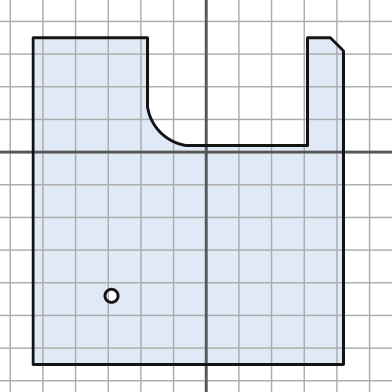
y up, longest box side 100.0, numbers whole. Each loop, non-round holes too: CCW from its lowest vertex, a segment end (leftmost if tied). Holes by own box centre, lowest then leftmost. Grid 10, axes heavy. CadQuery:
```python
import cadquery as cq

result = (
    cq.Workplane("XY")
    .moveTo(-53.0, -65.0)
    .lineTo(42.0, -65.0)
    .lineTo(42.0, 31.0)
    .lineTo(38.0, 35.0)
    .lineTo(31.0, 35.0)
    .lineTo(31.0, 2.0)
    .lineTo(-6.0, 2.0)
    .threePointArc((-14.0, 6.0), (-18.0, 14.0))
    .lineTo(-18.0, 35.0)
    .lineTo(-53.0, 35.0)
    .close()
    .moveTo(-29.0, -44.0)
    .circle(2.0)
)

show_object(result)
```